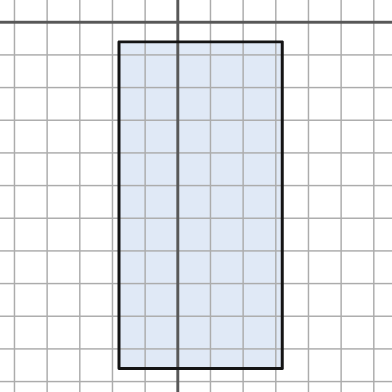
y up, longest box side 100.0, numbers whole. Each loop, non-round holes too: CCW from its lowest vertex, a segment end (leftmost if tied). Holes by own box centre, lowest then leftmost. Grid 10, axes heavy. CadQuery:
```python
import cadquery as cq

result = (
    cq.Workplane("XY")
    .moveTo(-18.0, -106.0)
    .lineTo(32.0, -106.0)
    .lineTo(32.0, -6.0)
    .lineTo(-18.0, -6.0)
    .close()
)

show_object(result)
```